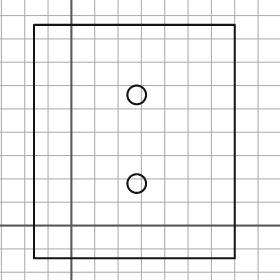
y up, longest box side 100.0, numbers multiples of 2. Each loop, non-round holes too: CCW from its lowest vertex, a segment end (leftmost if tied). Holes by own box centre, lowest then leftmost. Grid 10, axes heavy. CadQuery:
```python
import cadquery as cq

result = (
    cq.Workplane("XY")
    .moveTo(-16.0, -14.0)
    .lineTo(70.0, -14.0)
    .lineTo(70.0, 86.0)
    .lineTo(-16.0, 86.0)
    .close()
    .moveTo(28.0, 18.0)
    .circle(4.0)
    .moveTo(28.0, 56.0)
    .circle(4.0)
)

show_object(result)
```